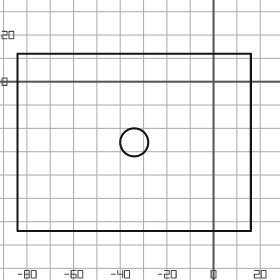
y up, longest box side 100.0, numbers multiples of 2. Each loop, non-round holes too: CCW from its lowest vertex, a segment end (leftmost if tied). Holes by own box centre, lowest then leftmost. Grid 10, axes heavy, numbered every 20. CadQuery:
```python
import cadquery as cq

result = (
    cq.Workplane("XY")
    .moveTo(-84.0, -64.0)
    .lineTo(16.0, -64.0)
    .lineTo(16.0, 12.0)
    .lineTo(-84.0, 12.0)
    .close()
    .moveTo(-34.0, -26.0)
    .circle(6.0)
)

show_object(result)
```